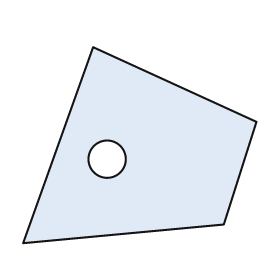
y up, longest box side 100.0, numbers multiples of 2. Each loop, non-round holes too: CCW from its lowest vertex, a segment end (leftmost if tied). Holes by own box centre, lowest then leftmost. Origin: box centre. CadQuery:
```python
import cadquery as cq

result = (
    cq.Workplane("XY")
    .moveTo(-50.0, -42.0)
    .lineTo(36.0, -34.0)
    .lineTo(50.0, 10.0)
    .lineTo(-20.0, 42.0)
    .close()
    .moveTo(-14.0, -6.0)
    .circle(8.0)
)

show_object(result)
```